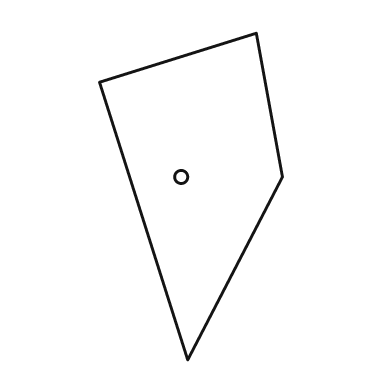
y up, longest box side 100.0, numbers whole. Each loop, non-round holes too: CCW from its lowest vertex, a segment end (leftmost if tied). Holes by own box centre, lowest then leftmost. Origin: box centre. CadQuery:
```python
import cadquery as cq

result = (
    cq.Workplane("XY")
    .moveTo(-1.0, -50.0)
    .lineTo(28.0, 6.0)
    .lineTo(20.0, 50.0)
    .lineTo(-28.0, 35.0)
    .close()
    .moveTo(-3.0, 6.0)
    .circle(2.0)
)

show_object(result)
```